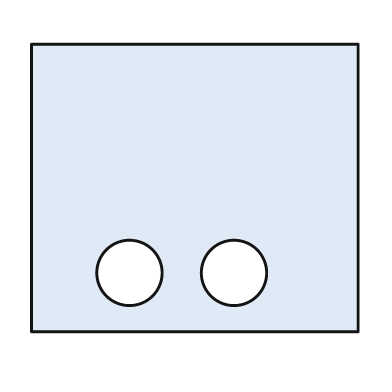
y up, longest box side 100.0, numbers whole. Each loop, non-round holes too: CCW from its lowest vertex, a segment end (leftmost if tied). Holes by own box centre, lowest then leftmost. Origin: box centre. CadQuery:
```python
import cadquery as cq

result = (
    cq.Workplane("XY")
    .moveTo(-50.0, -44.0)
    .lineTo(50.0, -44.0)
    .lineTo(50.0, 44.0)
    .lineTo(-50.0, 44.0)
    .close()
    .moveTo(-20.0, -26.0)
    .circle(10.0)
    .moveTo(12.0, -26.0)
    .circle(10.0)
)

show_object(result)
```